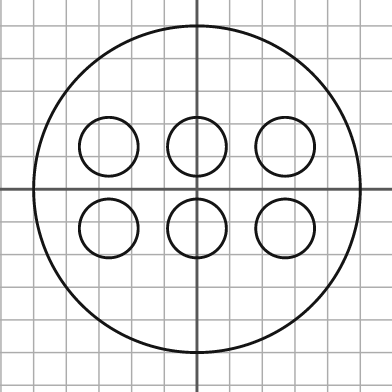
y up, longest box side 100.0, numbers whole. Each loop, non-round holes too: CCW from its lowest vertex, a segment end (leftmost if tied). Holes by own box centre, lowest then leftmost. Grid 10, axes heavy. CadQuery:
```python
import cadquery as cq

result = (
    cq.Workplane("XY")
    .moveTo(0.0, 0.0)
    .circle(50.0)
    .moveTo(-27.0, -12.0)
    .circle(9.0)
    .moveTo(0.0, -12.0)
    .circle(9.0)
    .moveTo(27.0, -12.0)
    .circle(9.0)
    .moveTo(-27.0, 13.0)
    .circle(9.0)
    .moveTo(0.0, 13.0)
    .circle(9.0)
    .moveTo(27.0, 13.0)
    .circle(9.0)
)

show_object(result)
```